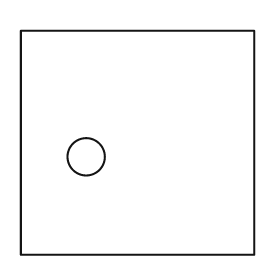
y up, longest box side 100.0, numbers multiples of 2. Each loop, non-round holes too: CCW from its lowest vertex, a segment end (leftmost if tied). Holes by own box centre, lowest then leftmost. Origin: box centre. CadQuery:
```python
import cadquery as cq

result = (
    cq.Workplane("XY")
    .moveTo(-50.0, -48.0)
    .lineTo(50.0, -48.0)
    .lineTo(50.0, 48.0)
    .lineTo(-50.0, 48.0)
    .close()
    .moveTo(-22.0, -6.0)
    .circle(8.0)
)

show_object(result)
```